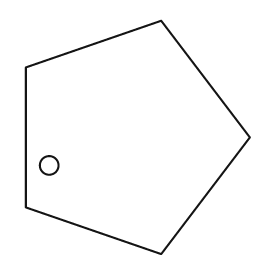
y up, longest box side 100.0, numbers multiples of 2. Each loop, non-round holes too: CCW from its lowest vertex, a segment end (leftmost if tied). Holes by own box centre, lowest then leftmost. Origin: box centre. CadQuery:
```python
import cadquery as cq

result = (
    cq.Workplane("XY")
    .moveTo(10.0, -50.0)
    .lineTo(48.0, 0.0)
    .lineTo(10.0, 50.0)
    .lineTo(-48.0, 30.0)
    .lineTo(-48.0, -30.0)
    .close()
    .moveTo(-38.0, -12.0)
    .circle(4.0)
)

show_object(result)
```